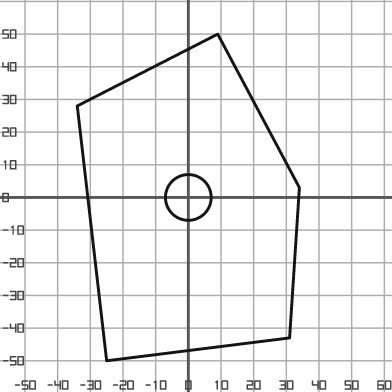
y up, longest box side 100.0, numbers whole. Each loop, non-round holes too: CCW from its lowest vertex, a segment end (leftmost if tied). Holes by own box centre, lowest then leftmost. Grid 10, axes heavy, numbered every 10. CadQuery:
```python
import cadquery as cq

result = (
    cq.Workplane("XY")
    .moveTo(-25.0, -50.0)
    .lineTo(31.0, -43.0)
    .lineTo(34.0, 3.0)
    .lineTo(9.0, 50.0)
    .lineTo(-34.0, 28.0)
    .close()
    .moveTo(0.0, 0.0)
    .circle(7.0)
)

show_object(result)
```